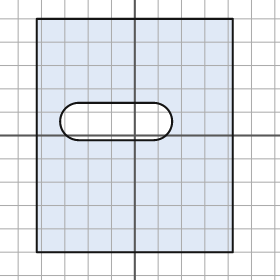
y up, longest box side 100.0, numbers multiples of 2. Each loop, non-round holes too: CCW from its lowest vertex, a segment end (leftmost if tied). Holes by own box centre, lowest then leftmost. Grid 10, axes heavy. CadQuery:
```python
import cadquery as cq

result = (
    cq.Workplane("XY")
    .moveTo(-42.0, -50.0)
    .lineTo(42.0, -50.0)
    .lineTo(42.0, 50.0)
    .lineTo(-42.0, 50.0)
    .close()
    .moveTo(-24.0, -2.0)
    .lineTo(8.0, -2.0)
    .threePointArc((16.0, 6.0), (8.0, 14.0))
    .lineTo(-24.0, 14.0)
    .threePointArc((-32.0, 6.0), (-24.0, -2.0))
    .close()
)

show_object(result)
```